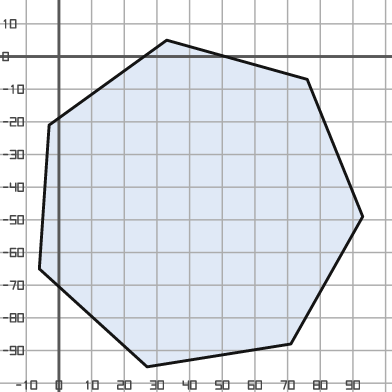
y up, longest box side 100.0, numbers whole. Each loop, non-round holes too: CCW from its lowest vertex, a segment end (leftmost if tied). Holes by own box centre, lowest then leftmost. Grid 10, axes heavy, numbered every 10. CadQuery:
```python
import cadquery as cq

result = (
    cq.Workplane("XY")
    .moveTo(27.0, -95.0)
    .lineTo(71.0, -88.0)
    .lineTo(93.0, -49.0)
    .lineTo(76.0, -7.0)
    .lineTo(33.0, 5.0)
    .lineTo(-3.0, -21.0)
    .lineTo(-6.0, -65.0)
    .close()
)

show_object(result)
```